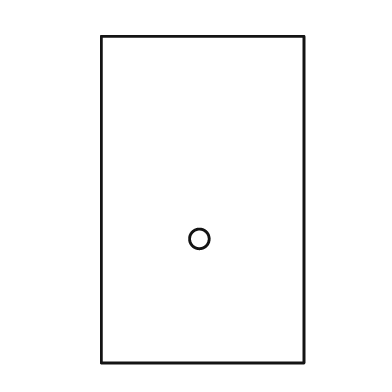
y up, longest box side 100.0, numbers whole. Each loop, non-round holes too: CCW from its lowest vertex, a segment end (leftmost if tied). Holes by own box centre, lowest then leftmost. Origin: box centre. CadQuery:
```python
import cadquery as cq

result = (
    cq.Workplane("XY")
    .moveTo(-31.0, -50.0)
    .lineTo(31.0, -50.0)
    .lineTo(31.0, 50.0)
    .lineTo(-31.0, 50.0)
    .close()
    .moveTo(-1.0, -12.0)
    .circle(3.0)
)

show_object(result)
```